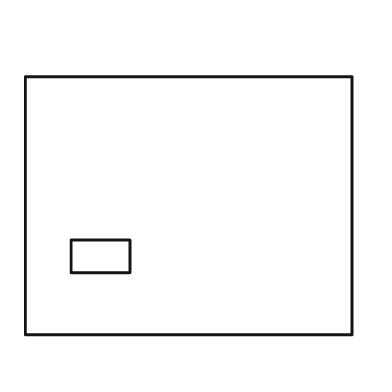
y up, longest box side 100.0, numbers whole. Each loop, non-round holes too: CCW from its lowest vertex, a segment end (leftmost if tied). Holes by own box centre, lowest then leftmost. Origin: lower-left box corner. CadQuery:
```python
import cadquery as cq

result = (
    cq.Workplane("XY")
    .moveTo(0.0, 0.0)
    .lineTo(100.0, 0.0)
    .lineTo(100.0, 79.0)
    .lineTo(0.0, 79.0)
    .close()
    .moveTo(14.0, 19.0)
    .lineTo(32.0, 19.0)
    .lineTo(32.0, 29.0)
    .lineTo(14.0, 29.0)
    .close()
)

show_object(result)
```